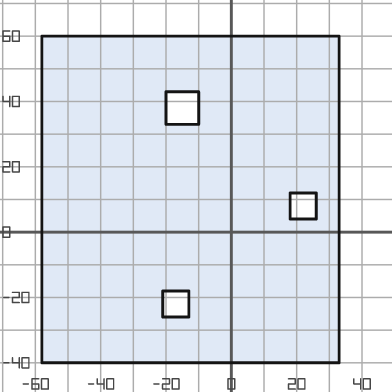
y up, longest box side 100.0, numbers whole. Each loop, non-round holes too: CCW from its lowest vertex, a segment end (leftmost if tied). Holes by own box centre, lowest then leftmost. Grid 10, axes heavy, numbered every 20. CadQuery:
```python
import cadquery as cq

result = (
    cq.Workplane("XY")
    .moveTo(-58.0, -40.0)
    .lineTo(33.0, -40.0)
    .lineTo(33.0, 60.0)
    .lineTo(-58.0, 60.0)
    .close()
    .moveTo(-21.0, -26.0)
    .lineTo(-13.0, -26.0)
    .lineTo(-13.0, -18.0)
    .lineTo(-21.0, -18.0)
    .close()
    .moveTo(18.0, 4.0)
    .lineTo(26.0, 4.0)
    .lineTo(26.0, 12.0)
    .lineTo(18.0, 12.0)
    .close()
    .moveTo(-20.0, 33.0)
    .lineTo(-10.0, 33.0)
    .lineTo(-10.0, 43.0)
    .lineTo(-20.0, 43.0)
    .close()
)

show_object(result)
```